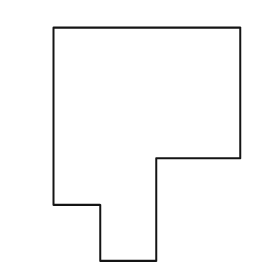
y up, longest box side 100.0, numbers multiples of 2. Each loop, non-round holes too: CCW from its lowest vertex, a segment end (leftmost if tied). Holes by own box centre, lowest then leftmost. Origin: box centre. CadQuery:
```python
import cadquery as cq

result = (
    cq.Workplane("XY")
    .moveTo(-20.0, -50.0)
    .lineTo(4.0, -50.0)
    .lineTo(4.0, -6.0)
    .lineTo(40.0, -6.0)
    .lineTo(40.0, 50.0)
    .lineTo(-40.0, 50.0)
    .lineTo(-40.0, -26.0)
    .lineTo(-20.0, -26.0)
    .close()
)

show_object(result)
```